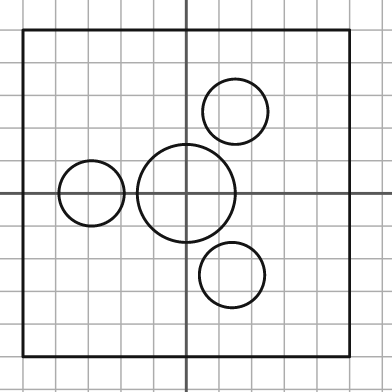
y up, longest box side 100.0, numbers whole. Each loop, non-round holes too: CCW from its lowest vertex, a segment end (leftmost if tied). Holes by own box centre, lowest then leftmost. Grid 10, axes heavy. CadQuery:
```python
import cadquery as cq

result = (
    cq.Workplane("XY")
    .moveTo(-50.0, -50.0)
    .lineTo(50.0, -50.0)
    .lineTo(50.0, 50.0)
    .lineTo(-50.0, 50.0)
    .close()
    .moveTo(14.0, -25.0)
    .circle(10.0)
    .moveTo(-29.0, 0.0)
    .circle(10.0)
    .moveTo(0.0, 0.0)
    .circle(15.0)
    .moveTo(15.0, 25.0)
    .circle(10.0)
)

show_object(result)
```